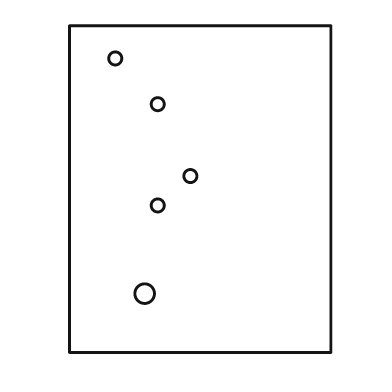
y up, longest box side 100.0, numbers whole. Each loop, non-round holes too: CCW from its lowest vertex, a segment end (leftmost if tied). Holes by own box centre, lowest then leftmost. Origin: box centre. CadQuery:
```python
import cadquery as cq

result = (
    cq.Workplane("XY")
    .moveTo(-40.0, -50.0)
    .lineTo(40.0, -50.0)
    .lineTo(40.0, 50.0)
    .lineTo(-40.0, 50.0)
    .close()
    .moveTo(-17.0, -32.0)
    .circle(3.0)
    .moveTo(-13.0, -5.0)
    .circle(2.0)
    .moveTo(-3.0, 4.0)
    .circle(2.0)
    .moveTo(-13.0, 26.0)
    .circle(2.0)
    .moveTo(-26.0, 40.0)
    .circle(2.0)
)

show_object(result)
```